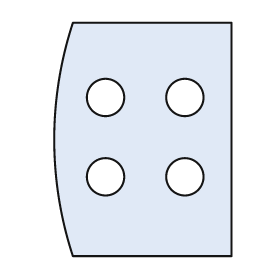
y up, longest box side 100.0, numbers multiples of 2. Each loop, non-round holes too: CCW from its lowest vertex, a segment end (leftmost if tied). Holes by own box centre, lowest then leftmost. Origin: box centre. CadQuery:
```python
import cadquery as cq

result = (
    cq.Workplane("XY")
    .moveTo(-30.0, -50.0)
    .lineTo(38.0, -50.0)
    .lineTo(38.0, 50.0)
    .lineTo(-30.0, 50.0)
    .threePointArc((-38.0, 0.0), (-30.0, -50.0))
    .close()
    .moveTo(-16.0, -16.0)
    .circle(8.0)
    .moveTo(18.0, -16.0)
    .circle(8.0)
    .moveTo(-16.0, 18.0)
    .circle(8.0)
    .moveTo(18.0, 18.0)
    .circle(8.0)
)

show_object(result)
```